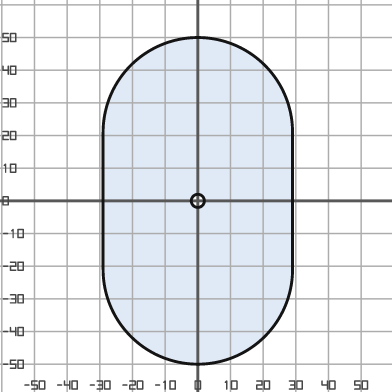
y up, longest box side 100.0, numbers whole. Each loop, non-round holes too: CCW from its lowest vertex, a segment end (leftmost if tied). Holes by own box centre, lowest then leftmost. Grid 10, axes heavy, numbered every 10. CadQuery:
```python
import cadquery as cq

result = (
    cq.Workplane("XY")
    .moveTo(-29.0, -21.0)
    .threePointArc((0.0, -50.0), (29.0, -21.0))
    .lineTo(29.0, 21.0)
    .threePointArc((0.0, 50.0), (-29.0, 21.0))
    .close()
    .moveTo(0.0, 0.0)
    .circle(2.0)
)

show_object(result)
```